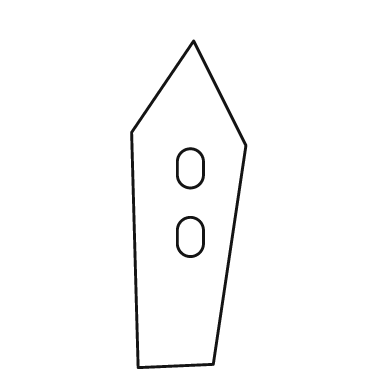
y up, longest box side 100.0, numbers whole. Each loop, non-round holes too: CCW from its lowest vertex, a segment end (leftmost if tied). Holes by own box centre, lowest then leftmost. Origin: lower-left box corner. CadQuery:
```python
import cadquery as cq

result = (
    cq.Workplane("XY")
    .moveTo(2.0, 0.0)
    .lineTo(25.0, 1.0)
    .lineTo(35.0, 68.0)
    .lineTo(19.0, 100.0)
    .lineTo(0.0, 72.0)
    .close()
    .moveTo(14.0, 38.0)
    .threePointArc((18.0, 34.0), (22.0, 38.0))
    .lineTo(22.0, 42.0)
    .threePointArc((18.0, 46.0), (14.0, 42.0))
    .close()
    .moveTo(14.0, 59.0)
    .threePointArc((18.0, 55.0), (22.0, 59.0))
    .lineTo(22.0, 63.0)
    .threePointArc((18.0, 67.0), (14.0, 63.0))
    .close()
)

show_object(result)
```